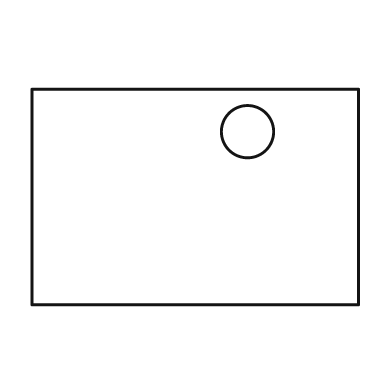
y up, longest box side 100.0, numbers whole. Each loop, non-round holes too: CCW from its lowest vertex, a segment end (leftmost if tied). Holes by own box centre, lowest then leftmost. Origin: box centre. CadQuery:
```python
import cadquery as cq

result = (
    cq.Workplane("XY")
    .moveTo(-50.0, -33.0)
    .lineTo(50.0, -33.0)
    .lineTo(50.0, 33.0)
    .lineTo(-50.0, 33.0)
    .close()
    .moveTo(16.0, 20.0)
    .circle(8.0)
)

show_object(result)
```